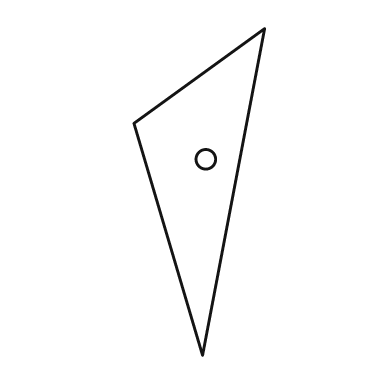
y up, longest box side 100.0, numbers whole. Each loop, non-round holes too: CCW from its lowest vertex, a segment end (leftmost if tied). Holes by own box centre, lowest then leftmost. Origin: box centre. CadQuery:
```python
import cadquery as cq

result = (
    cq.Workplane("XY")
    .moveTo(1.0, -50.0)
    .lineTo(20.0, 50.0)
    .lineTo(-20.0, 21.0)
    .close()
    .moveTo(2.0, 10.0)
    .circle(3.0)
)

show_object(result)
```